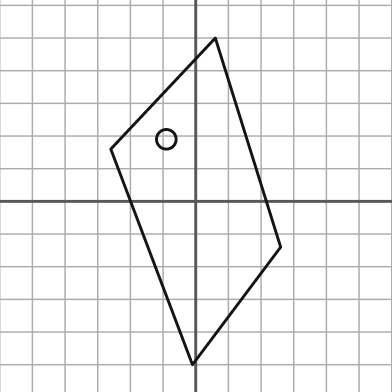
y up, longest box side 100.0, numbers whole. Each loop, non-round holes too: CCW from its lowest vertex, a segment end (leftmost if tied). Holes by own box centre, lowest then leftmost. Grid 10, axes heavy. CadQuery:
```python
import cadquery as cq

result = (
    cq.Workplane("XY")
    .moveTo(-1.0, -50.0)
    .lineTo(26.0, -14.0)
    .lineTo(6.0, 50.0)
    .lineTo(-26.0, 16.0)
    .close()
    .moveTo(-9.0, 19.0)
    .circle(3.0)
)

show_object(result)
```